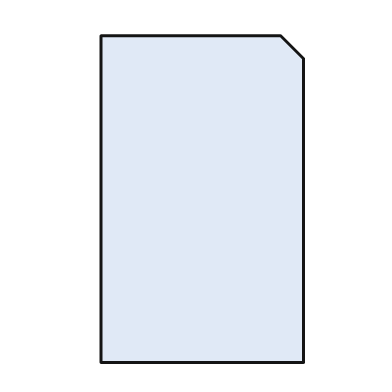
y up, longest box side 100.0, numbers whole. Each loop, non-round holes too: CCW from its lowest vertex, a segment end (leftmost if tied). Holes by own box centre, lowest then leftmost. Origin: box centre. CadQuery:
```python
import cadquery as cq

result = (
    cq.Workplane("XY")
    .moveTo(-31.0, -50.0)
    .lineTo(31.0, -50.0)
    .lineTo(31.0, 43.0)
    .lineTo(24.0, 50.0)
    .lineTo(-31.0, 50.0)
    .close()
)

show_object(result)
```